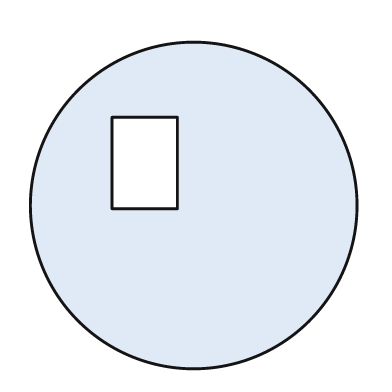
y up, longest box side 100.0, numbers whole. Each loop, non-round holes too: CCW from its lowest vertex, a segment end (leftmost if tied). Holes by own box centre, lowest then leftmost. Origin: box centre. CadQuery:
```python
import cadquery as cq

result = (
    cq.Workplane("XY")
    .moveTo(0.0, 0.0)
    .circle(50.0)
    .moveTo(-25.0, -1.0)
    .lineTo(-5.0, -1.0)
    .lineTo(-5.0, 27.0)
    .lineTo(-25.0, 27.0)
    .close()
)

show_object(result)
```